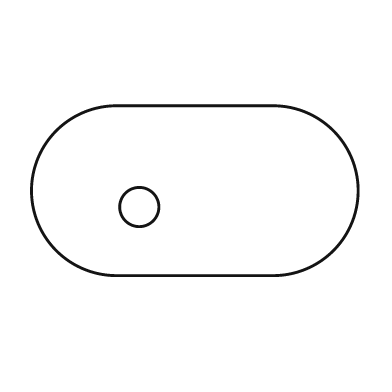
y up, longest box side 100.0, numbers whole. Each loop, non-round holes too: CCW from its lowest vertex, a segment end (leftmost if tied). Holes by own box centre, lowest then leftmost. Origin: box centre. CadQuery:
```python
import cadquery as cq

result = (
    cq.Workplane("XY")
    .moveTo(-24.0, -26.0)
    .lineTo(24.0, -26.0)
    .threePointArc((50.0, 0.0), (24.0, 26.0))
    .lineTo(-24.0, 26.0)
    .threePointArc((-50.0, 0.0), (-24.0, -26.0))
    .close()
    .moveTo(-17.0, -5.0)
    .circle(6.0)
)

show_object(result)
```